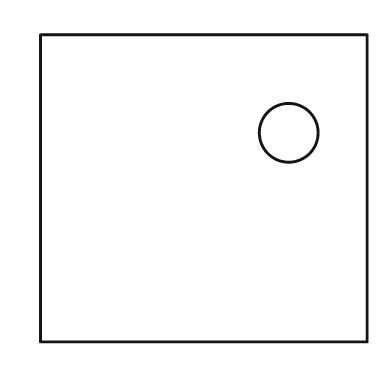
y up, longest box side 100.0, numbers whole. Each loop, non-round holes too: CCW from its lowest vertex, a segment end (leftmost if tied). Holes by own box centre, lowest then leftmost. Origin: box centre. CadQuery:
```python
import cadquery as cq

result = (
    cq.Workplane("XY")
    .moveTo(-50.0, -47.0)
    .lineTo(50.0, -47.0)
    .lineTo(50.0, 47.0)
    .lineTo(-50.0, 47.0)
    .close()
    .moveTo(26.0, 17.0)
    .circle(9.0)
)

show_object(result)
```